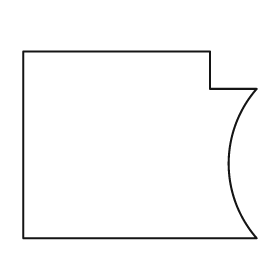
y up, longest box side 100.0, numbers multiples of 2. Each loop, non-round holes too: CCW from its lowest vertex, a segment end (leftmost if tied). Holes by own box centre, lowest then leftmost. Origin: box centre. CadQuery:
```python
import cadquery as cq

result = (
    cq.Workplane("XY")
    .moveTo(-50.0, -40.0)
    .lineTo(50.0, -40.0)
    .threePointArc((38.0, -8.0), (50.0, 24.0))
    .lineTo(30.0, 24.0)
    .lineTo(30.0, 40.0)
    .lineTo(-50.0, 40.0)
    .close()
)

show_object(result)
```